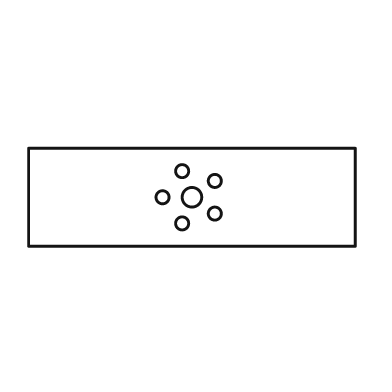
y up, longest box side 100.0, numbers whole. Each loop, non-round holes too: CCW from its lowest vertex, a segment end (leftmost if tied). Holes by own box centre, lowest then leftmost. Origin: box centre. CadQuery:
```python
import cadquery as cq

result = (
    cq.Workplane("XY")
    .moveTo(-50.0, -15.0)
    .lineTo(50.0, -15.0)
    .lineTo(50.0, 15.0)
    .lineTo(-50.0, 15.0)
    .close()
    .moveTo(-3.0, -8.0)
    .circle(2.0)
    .moveTo(7.0, -5.0)
    .circle(2.0)
    .moveTo(-9.0, 0.0)
    .circle(2.0)
    .moveTo(0.0, 0.0)
    .circle(3.0)
    .moveTo(7.0, 5.0)
    .circle(2.0)
    .moveTo(-3.0, 8.0)
    .circle(2.0)
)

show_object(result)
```